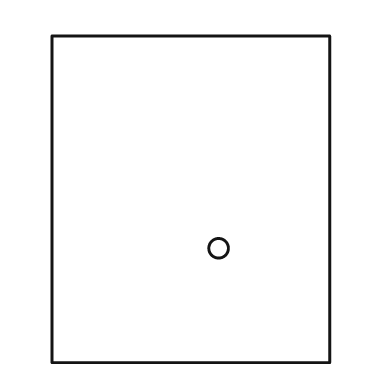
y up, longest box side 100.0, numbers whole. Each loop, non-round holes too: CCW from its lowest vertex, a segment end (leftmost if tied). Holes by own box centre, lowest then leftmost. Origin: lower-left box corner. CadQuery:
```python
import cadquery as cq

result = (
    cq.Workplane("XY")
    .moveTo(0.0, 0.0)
    .lineTo(85.0, 0.0)
    .lineTo(85.0, 100.0)
    .lineTo(0.0, 100.0)
    .close()
    .moveTo(51.0, 35.0)
    .circle(3.0)
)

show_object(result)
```